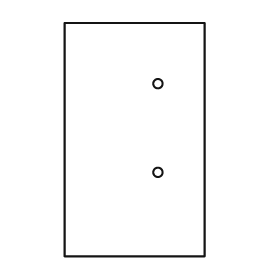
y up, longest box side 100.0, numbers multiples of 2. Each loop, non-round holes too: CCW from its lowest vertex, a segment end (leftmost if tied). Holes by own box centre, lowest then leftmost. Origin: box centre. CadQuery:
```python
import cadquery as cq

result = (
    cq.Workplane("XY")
    .moveTo(-30.0, -50.0)
    .lineTo(30.0, -50.0)
    .lineTo(30.0, 50.0)
    .lineTo(-30.0, 50.0)
    .close()
    .moveTo(10.0, -14.0)
    .circle(2.0)
    .moveTo(10.0, 24.0)
    .circle(2.0)
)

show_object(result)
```